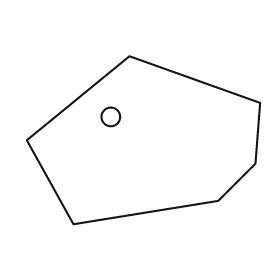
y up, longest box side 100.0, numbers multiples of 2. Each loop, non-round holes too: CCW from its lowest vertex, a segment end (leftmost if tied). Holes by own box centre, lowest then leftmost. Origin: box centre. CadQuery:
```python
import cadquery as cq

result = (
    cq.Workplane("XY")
    .moveTo(-30.0, -36.0)
    .lineTo(32.0, -26.0)
    .lineTo(48.0, -10.0)
    .lineTo(50.0, 16.0)
    .lineTo(-6.0, 36.0)
    .lineTo(-50.0, 0.0)
    .close()
    .moveTo(-14.0, 10.0)
    .circle(4.0)
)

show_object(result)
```